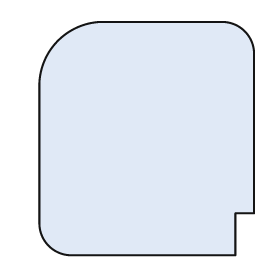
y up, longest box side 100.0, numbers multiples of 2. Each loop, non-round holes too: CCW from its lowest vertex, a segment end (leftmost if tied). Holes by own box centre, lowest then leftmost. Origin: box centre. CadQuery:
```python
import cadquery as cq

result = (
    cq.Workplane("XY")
    .moveTo(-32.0, -50.0)
    .lineTo(38.0, -50.0)
    .lineTo(38.0, -32.0)
    .lineTo(46.0, -32.0)
    .lineTo(46.0, 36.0)
    .threePointArc((42.0, 46.0), (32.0, 50.0))
    .lineTo(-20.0, 50.0)
    .threePointArc((-38.0, 42.0), (-46.0, 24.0))
    .lineTo(-46.0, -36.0)
    .threePointArc((-42.0, -46.0), (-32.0, -50.0))
    .close()
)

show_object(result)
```